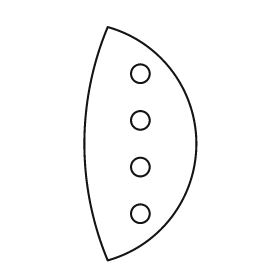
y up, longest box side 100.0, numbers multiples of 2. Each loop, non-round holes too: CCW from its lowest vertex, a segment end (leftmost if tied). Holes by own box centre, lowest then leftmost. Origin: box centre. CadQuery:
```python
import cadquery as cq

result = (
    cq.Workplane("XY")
    .moveTo(-14.0, -50.0)
    .threePointArc((24.0, 0.0), (-14.0, 50.0))
    .threePointArc((-24.0, 0.0), (-14.0, -50.0))
    .close()
    .moveTo(0.0, -30.0)
    .circle(4.0)
    .moveTo(0.0, -10.0)
    .circle(4.0)
    .moveTo(0.0, 10.0)
    .circle(4.0)
    .moveTo(0.0, 30.0)
    .circle(4.0)
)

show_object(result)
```